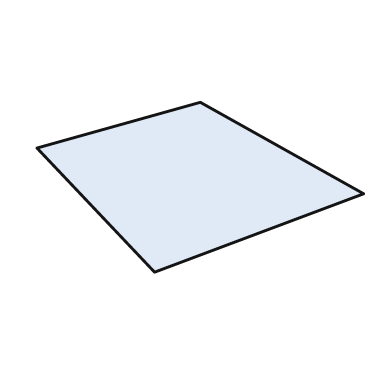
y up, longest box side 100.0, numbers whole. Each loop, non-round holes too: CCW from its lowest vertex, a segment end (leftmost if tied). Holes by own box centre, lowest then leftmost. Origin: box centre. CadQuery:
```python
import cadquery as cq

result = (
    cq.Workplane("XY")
    .moveTo(-14.0, -26.0)
    .lineTo(50.0, -2.0)
    .lineTo(0.0, 26.0)
    .lineTo(-50.0, 12.0)
    .close()
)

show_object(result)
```